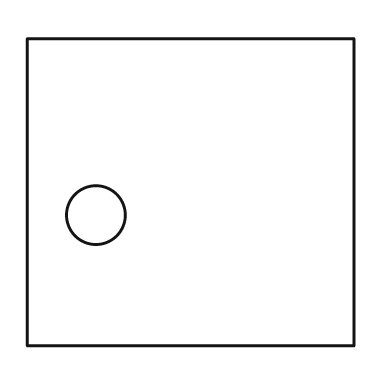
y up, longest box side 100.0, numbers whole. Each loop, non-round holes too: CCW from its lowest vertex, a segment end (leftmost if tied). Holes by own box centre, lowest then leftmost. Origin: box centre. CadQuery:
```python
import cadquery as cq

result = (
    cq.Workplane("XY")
    .moveTo(-50.0, -47.0)
    .lineTo(50.0, -47.0)
    .lineTo(50.0, 47.0)
    .lineTo(-50.0, 47.0)
    .close()
    .moveTo(-29.0, -7.0)
    .circle(9.0)
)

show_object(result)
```